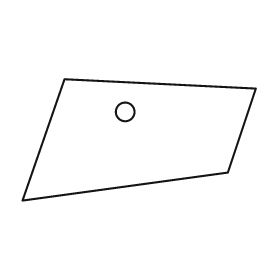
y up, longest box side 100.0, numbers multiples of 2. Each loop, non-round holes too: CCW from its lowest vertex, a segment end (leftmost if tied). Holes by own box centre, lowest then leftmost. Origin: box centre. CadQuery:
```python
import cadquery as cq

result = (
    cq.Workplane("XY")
    .moveTo(-50.0, -26.0)
    .lineTo(38.0, -14.0)
    .lineTo(50.0, 22.0)
    .lineTo(-32.0, 26.0)
    .close()
    .moveTo(-6.0, 12.0)
    .circle(4.0)
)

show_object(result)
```